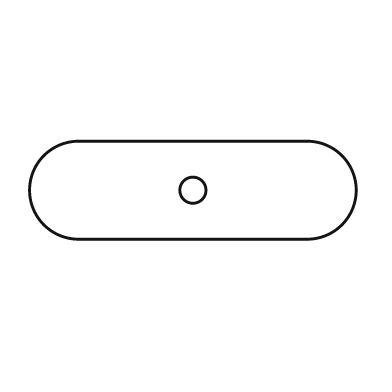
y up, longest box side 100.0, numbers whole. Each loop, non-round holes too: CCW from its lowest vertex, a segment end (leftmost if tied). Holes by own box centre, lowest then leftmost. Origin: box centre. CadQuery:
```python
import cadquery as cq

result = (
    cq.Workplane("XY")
    .moveTo(-35.0, -15.0)
    .lineTo(35.0, -15.0)
    .threePointArc((50.0, 0.0), (35.0, 15.0))
    .lineTo(-35.0, 15.0)
    .threePointArc((-50.0, 0.0), (-35.0, -15.0))
    .close()
    .moveTo(0.0, 0.0)
    .circle(4.0)
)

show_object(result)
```